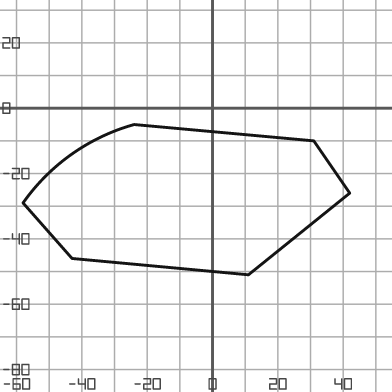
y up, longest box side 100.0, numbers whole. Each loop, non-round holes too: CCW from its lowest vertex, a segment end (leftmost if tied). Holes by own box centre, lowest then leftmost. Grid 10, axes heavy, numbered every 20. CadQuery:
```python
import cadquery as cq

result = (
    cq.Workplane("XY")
    .moveTo(11.0, -51.0)
    .lineTo(42.0, -26.0)
    .lineTo(31.0, -10.0)
    .lineTo(-24.0, -5.0)
    .threePointArc((-43.0, -14.0), (-58.0, -29.0))
    .lineTo(-43.0, -46.0)
    .close()
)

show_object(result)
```